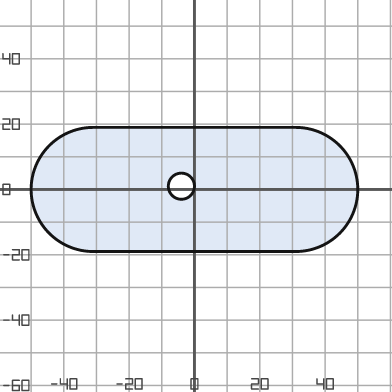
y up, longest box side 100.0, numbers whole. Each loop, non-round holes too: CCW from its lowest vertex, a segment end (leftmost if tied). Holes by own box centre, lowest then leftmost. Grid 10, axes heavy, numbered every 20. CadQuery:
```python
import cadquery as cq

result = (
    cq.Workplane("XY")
    .moveTo(-31.0, -19.0)
    .lineTo(31.0, -19.0)
    .threePointArc((50.0, 0.0), (31.0, 19.0))
    .lineTo(-31.0, 19.0)
    .threePointArc((-50.0, 0.0), (-31.0, -19.0))
    .close()
    .moveTo(-4.0, 1.0)
    .circle(4.0)
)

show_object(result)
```